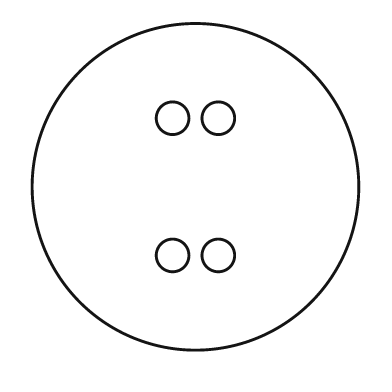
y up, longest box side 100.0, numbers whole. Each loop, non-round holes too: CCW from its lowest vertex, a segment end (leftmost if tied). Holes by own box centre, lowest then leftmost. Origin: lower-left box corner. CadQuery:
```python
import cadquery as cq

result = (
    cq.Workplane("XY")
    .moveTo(50.0, 50.0)
    .circle(50.0)
    .moveTo(43.0, 29.0)
    .circle(5.0)
    .moveTo(57.0, 29.0)
    .circle(5.0)
    .moveTo(43.0, 71.0)
    .circle(5.0)
    .moveTo(57.0, 71.0)
    .circle(5.0)
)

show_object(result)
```